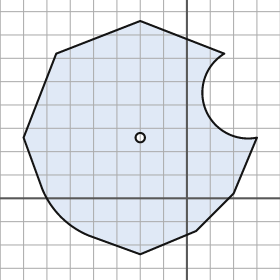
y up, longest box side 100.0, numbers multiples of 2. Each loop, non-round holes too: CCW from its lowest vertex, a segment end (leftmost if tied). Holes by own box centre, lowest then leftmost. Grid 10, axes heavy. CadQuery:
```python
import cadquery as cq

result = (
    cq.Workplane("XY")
    .moveTo(-20.0, -24.0)
    .lineTo(4.0, -14.0)
    .lineTo(20.0, 2.0)
    .lineTo(30.0, 26.0)
    .threePointArc((8.0, 38.0), (16.0, 62.0))
    .lineTo(-20.0, 76.0)
    .lineTo(-56.0, 62.0)
    .lineTo(-70.0, 26.0)
    .lineTo(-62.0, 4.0)
    .threePointArc((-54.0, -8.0), (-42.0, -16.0))
    .close()
    .moveTo(-20.0, 26.0)
    .circle(2.0)
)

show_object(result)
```